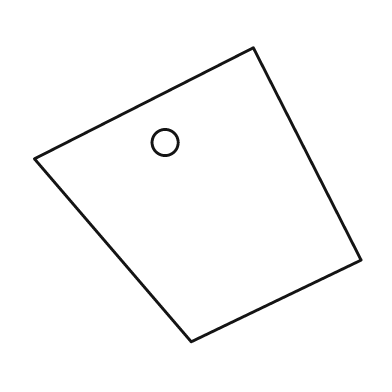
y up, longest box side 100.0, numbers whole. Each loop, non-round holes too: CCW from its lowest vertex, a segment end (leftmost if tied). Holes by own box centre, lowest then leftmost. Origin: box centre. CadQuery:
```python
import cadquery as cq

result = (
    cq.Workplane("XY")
    .moveTo(-2.0, -45.0)
    .lineTo(50.0, -20.0)
    .lineTo(17.0, 45.0)
    .lineTo(-50.0, 11.0)
    .close()
    .moveTo(-10.0, 16.0)
    .circle(4.0)
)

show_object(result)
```